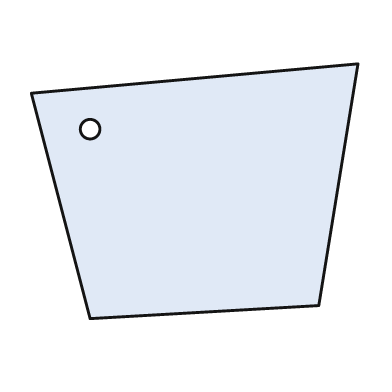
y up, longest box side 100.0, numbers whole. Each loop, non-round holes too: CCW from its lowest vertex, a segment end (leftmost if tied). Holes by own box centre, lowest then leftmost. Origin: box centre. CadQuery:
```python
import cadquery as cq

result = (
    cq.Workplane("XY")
    .moveTo(-32.0, -39.0)
    .lineTo(38.0, -35.0)
    .lineTo(50.0, 39.0)
    .lineTo(-50.0, 30.0)
    .close()
    .moveTo(-32.0, 19.0)
    .circle(3.0)
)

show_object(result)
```